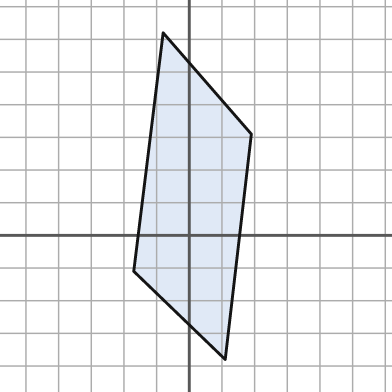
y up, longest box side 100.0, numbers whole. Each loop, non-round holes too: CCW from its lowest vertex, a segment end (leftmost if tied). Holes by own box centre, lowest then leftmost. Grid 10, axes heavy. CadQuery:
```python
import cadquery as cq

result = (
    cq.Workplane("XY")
    .moveTo(11.0, -38.0)
    .lineTo(19.0, 31.0)
    .lineTo(-8.0, 62.0)
    .lineTo(-17.0, -11.0)
    .close()
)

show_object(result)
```